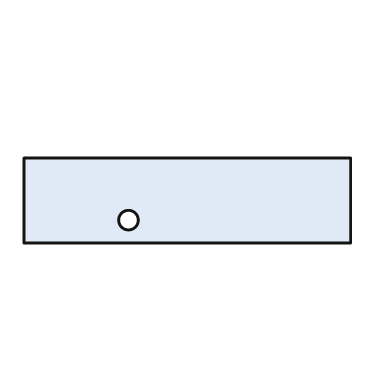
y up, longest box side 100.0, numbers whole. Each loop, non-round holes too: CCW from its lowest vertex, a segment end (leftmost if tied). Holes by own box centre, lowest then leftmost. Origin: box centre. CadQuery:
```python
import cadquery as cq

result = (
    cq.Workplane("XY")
    .moveTo(-50.0, -13.0)
    .lineTo(50.0, -13.0)
    .lineTo(50.0, 13.0)
    .lineTo(-50.0, 13.0)
    .close()
    .moveTo(-18.0, -6.0)
    .circle(3.0)
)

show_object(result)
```